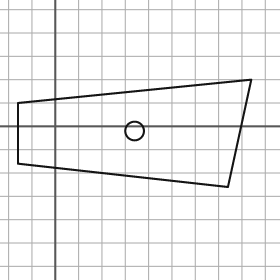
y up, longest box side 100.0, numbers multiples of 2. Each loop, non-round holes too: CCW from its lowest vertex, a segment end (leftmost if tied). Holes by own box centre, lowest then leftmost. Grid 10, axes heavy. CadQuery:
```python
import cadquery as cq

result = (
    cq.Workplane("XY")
    .moveTo(74.0, -26.0)
    .lineTo(84.0, 20.0)
    .lineTo(-16.0, 10.0)
    .lineTo(-16.0, -16.0)
    .close()
    .moveTo(34.0, -2.0)
    .circle(4.0)
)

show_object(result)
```